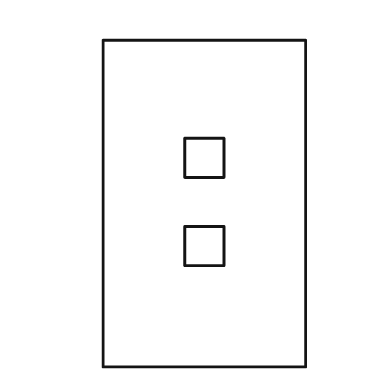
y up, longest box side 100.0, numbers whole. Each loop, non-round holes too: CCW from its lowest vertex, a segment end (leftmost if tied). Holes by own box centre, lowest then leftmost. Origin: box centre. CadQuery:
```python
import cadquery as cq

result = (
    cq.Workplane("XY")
    .moveTo(-31.0, -50.0)
    .lineTo(31.0, -50.0)
    .lineTo(31.0, 50.0)
    .lineTo(-31.0, 50.0)
    .close()
    .moveTo(-6.0, -19.0)
    .lineTo(6.0, -19.0)
    .lineTo(6.0, -7.0)
    .lineTo(-6.0, -7.0)
    .close()
    .moveTo(-6.0, 8.0)
    .lineTo(6.0, 8.0)
    .lineTo(6.0, 20.0)
    .lineTo(-6.0, 20.0)
    .close()
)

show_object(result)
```